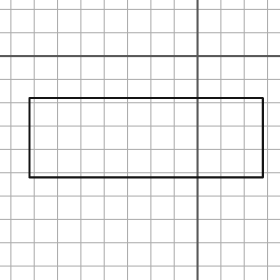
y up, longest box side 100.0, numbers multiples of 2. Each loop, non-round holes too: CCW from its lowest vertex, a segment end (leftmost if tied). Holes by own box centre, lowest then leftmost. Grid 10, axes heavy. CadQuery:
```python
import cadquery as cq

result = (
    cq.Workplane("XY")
    .moveTo(-72.0, -52.0)
    .lineTo(28.0, -52.0)
    .lineTo(28.0, -18.0)
    .lineTo(-72.0, -18.0)
    .close()
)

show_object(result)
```